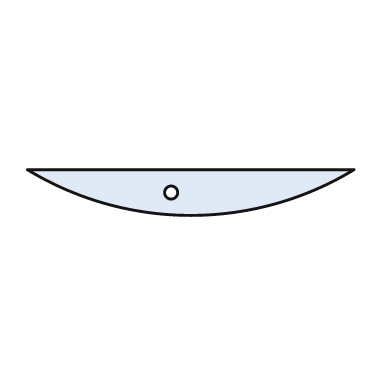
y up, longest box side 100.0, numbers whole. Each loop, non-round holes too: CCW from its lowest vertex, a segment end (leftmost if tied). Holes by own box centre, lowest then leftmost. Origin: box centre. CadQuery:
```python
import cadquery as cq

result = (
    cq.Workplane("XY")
    .moveTo(-50.0, 7.0)
    .threePointArc((0.0, -7.0), (50.0, 7.0))
    .close()
    .moveTo(-6.0, 0.0)
    .circle(2.0)
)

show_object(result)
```